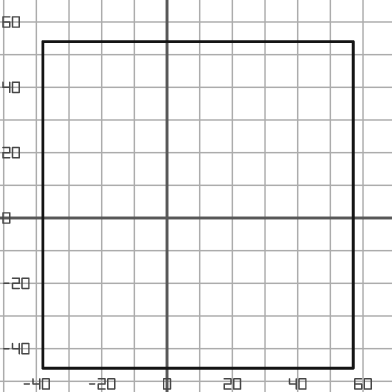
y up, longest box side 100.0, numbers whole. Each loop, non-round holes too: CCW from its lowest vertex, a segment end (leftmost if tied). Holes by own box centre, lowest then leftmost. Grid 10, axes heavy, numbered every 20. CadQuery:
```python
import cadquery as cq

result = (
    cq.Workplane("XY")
    .moveTo(-38.0, -46.0)
    .lineTo(57.0, -46.0)
    .lineTo(57.0, 54.0)
    .lineTo(-38.0, 54.0)
    .close()
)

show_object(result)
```